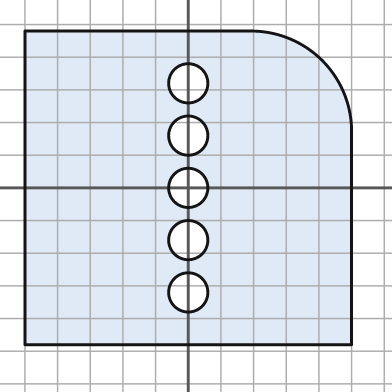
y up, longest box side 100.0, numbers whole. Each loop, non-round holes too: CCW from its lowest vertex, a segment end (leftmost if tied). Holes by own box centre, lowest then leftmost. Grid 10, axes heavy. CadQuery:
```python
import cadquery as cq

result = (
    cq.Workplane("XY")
    .moveTo(-50.0, -48.0)
    .lineTo(50.0, -48.0)
    .lineTo(50.0, 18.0)
    .threePointArc((41.0, 39.0), (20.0, 48.0))
    .lineTo(-50.0, 48.0)
    .close()
    .moveTo(0.0, -32.0)
    .circle(6.0)
    .moveTo(0.0, -16.0)
    .circle(6.0)
    .moveTo(0.0, 0.0)
    .circle(6.0)
    .moveTo(0.0, 16.0)
    .circle(6.0)
    .moveTo(0.0, 32.0)
    .circle(6.0)
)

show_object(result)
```